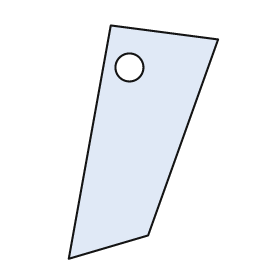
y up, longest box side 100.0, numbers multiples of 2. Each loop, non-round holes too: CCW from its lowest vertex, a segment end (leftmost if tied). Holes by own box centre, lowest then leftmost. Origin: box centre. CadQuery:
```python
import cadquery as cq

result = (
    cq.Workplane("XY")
    .moveTo(-32.0, -50.0)
    .lineTo(2.0, -40.0)
    .lineTo(32.0, 44.0)
    .lineTo(-14.0, 50.0)
    .close()
    .moveTo(-6.0, 32.0)
    .circle(6.0)
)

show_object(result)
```